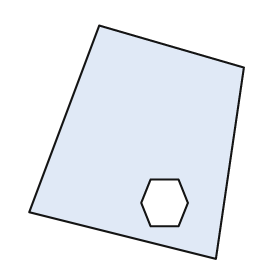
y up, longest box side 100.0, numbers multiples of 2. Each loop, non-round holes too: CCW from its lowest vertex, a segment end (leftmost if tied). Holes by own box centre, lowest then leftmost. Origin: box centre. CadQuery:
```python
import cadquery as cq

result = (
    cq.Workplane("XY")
    .moveTo(34.0, -50.0)
    .lineTo(46.0, 32.0)
    .lineTo(-16.0, 50.0)
    .lineTo(-46.0, -30.0)
    .close()
    .moveTo(6.0, -36.0)
    .lineTo(18.0, -36.0)
    .lineTo(22.0, -26.0)
    .lineTo(18.0, -16.0)
    .lineTo(6.0, -16.0)
    .lineTo(2.0, -26.0)
    .close()
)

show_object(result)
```